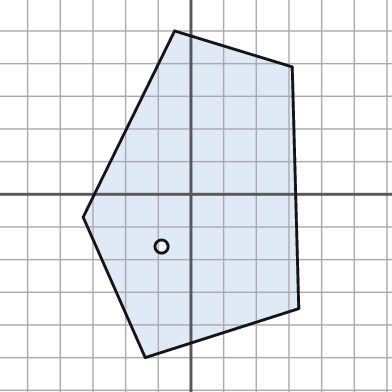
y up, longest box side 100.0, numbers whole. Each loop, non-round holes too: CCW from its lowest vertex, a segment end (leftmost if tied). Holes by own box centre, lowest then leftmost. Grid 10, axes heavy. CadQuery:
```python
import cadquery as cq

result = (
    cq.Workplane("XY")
    .moveTo(-14.0, -50.0)
    .lineTo(33.0, -35.0)
    .lineTo(31.0, 39.0)
    .lineTo(-5.0, 50.0)
    .lineTo(-33.0, -7.0)
    .close()
    .moveTo(-9.0, -16.0)
    .circle(2.0)
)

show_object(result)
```